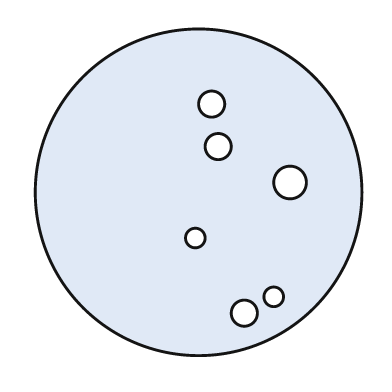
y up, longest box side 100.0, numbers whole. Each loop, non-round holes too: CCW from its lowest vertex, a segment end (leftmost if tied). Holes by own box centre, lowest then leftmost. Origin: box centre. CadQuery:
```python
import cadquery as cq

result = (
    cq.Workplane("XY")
    .moveTo(0.0, 0.0)
    .circle(50.0)
    .moveTo(14.0, -37.0)
    .circle(4.0)
    .moveTo(23.0, -32.0)
    .circle(3.0)
    .moveTo(-1.0, -14.0)
    .circle(3.0)
    .moveTo(28.0, 3.0)
    .circle(5.0)
    .moveTo(6.0, 14.0)
    .circle(4.0)
    .moveTo(4.0, 27.0)
    .circle(4.0)
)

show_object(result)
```